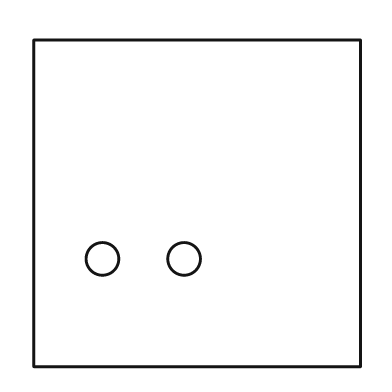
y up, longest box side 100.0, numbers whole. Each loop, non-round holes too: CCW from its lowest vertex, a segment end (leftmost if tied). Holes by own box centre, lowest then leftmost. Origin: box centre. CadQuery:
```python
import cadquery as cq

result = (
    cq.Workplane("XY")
    .moveTo(-50.0, -50.0)
    .lineTo(50.0, -50.0)
    .lineTo(50.0, 50.0)
    .lineTo(-50.0, 50.0)
    .close()
    .moveTo(-29.0, -17.0)
    .circle(5.0)
    .moveTo(-4.0, -17.0)
    .circle(5.0)
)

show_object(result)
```